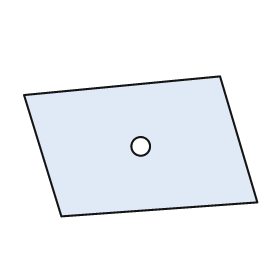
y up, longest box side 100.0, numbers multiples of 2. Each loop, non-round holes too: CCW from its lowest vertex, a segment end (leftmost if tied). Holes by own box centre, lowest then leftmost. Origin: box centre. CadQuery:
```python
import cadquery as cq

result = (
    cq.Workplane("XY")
    .moveTo(-34.0, -30.0)
    .lineTo(50.0, -24.0)
    .lineTo(34.0, 30.0)
    .lineTo(-50.0, 22.0)
    .close()
    .moveTo(0.0, 0.0)
    .circle(4.0)
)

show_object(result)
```